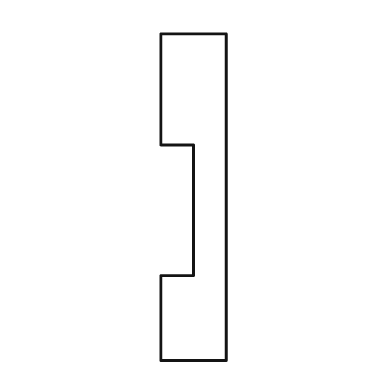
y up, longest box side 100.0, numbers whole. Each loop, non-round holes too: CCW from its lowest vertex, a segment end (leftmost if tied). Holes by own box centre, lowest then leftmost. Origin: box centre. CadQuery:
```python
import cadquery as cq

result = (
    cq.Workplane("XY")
    .moveTo(-10.0, -50.0)
    .lineTo(10.0, -50.0)
    .lineTo(10.0, 50.0)
    .lineTo(-10.0, 50.0)
    .lineTo(-10.0, 16.0)
    .lineTo(0.0, 16.0)
    .lineTo(0.0, -24.0)
    .lineTo(-10.0, -24.0)
    .close()
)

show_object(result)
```